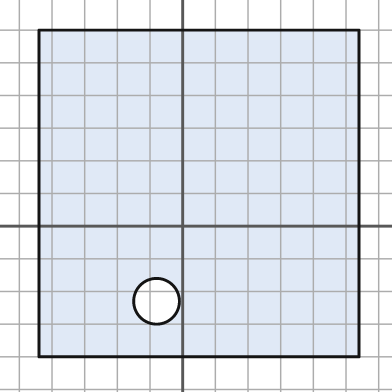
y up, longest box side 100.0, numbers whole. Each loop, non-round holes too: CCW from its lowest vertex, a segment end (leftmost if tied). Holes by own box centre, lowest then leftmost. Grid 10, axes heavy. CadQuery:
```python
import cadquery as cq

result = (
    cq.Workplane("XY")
    .moveTo(-44.0, -40.0)
    .lineTo(54.0, -40.0)
    .lineTo(54.0, 60.0)
    .lineTo(-44.0, 60.0)
    .close()
    .moveTo(-8.0, -23.0)
    .circle(7.0)
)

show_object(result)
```